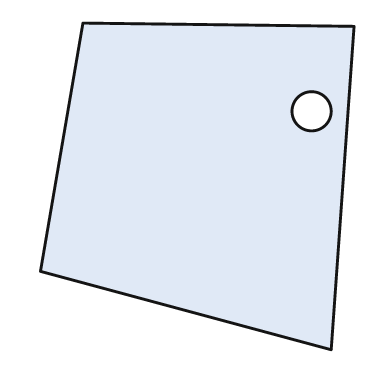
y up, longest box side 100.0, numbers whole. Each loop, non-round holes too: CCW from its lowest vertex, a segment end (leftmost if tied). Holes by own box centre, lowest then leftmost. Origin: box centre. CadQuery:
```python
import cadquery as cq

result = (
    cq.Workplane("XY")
    .moveTo(41.0, -50.0)
    .lineTo(48.0, 49.0)
    .lineTo(-35.0, 50.0)
    .lineTo(-48.0, -26.0)
    .close()
    .moveTo(35.0, 23.0)
    .circle(6.0)
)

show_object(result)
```